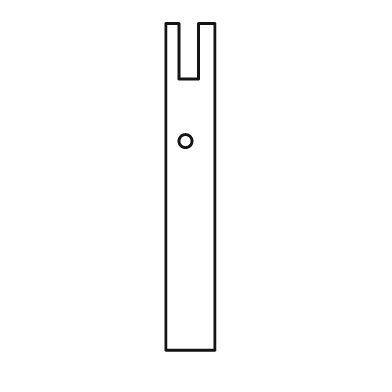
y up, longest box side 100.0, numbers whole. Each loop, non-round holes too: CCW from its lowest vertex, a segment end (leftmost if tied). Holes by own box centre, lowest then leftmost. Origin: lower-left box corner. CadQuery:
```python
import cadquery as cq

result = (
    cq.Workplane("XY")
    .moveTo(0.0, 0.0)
    .lineTo(15.0, 0.0)
    .lineTo(15.0, 100.0)
    .lineTo(10.0, 100.0)
    .lineTo(10.0, 83.0)
    .lineTo(4.0, 83.0)
    .lineTo(4.0, 100.0)
    .lineTo(0.0, 100.0)
    .close()
    .moveTo(6.0, 64.0)
    .circle(2.0)
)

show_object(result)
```